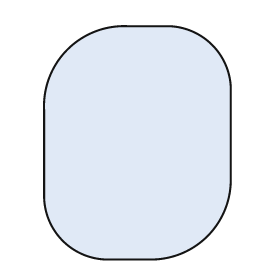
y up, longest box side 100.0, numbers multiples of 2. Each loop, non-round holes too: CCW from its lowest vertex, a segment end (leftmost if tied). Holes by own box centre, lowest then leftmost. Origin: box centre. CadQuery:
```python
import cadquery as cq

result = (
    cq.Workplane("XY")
    .moveTo(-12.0, -50.0)
    .lineTo(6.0, -50.0)
    .threePointArc((30.0, -40.0), (40.0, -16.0))
    .lineTo(40.0, 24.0)
    .threePointArc((32.0, 42.0), (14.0, 50.0))
    .lineTo(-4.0, 50.0)
    .threePointArc((-30.0, 40.0), (-40.0, 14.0))
    .lineTo(-40.0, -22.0)
    .threePointArc((-32.0, -42.0), (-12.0, -50.0))
    .close()
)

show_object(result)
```